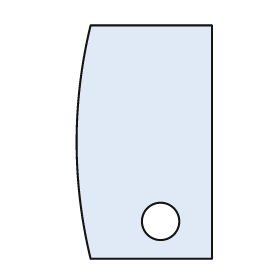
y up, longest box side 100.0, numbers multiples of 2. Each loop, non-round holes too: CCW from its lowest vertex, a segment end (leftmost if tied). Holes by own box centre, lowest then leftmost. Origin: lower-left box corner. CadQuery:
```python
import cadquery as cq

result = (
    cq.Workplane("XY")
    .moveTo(6.0, 0.0)
    .lineTo(58.0, 0.0)
    .lineTo(58.0, 100.0)
    .lineTo(6.0, 100.0)
    .threePointArc((0.0, 50.0), (6.0, 0.0))
    .close()
    .moveTo(36.0, 16.0)
    .circle(8.0)
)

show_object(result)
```